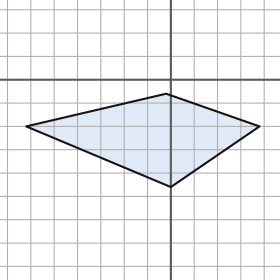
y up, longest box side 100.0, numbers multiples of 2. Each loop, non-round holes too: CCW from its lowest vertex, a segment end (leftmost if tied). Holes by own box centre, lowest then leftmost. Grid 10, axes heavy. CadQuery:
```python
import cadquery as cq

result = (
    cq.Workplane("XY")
    .moveTo(0.0, -46.0)
    .lineTo(38.0, -20.0)
    .lineTo(-2.0, -6.0)
    .lineTo(-62.0, -20.0)
    .close()
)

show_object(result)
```